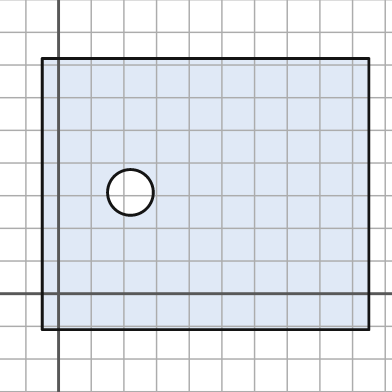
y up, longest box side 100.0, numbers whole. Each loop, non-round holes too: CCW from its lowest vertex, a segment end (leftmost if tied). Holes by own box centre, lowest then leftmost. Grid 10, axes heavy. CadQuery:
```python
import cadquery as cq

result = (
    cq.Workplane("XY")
    .moveTo(-5.0, -11.0)
    .lineTo(95.0, -11.0)
    .lineTo(95.0, 72.0)
    .lineTo(-5.0, 72.0)
    .close()
    .moveTo(22.0, 31.0)
    .circle(7.0)
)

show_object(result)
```